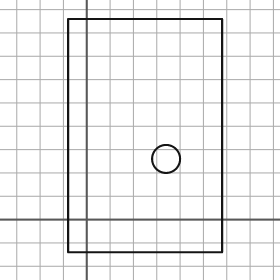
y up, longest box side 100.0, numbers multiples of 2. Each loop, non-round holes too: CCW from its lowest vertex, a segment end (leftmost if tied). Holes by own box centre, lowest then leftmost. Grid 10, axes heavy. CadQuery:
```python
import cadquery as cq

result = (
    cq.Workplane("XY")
    .moveTo(-8.0, -14.0)
    .lineTo(58.0, -14.0)
    .lineTo(58.0, 86.0)
    .lineTo(-8.0, 86.0)
    .close()
    .moveTo(34.0, 26.0)
    .circle(6.0)
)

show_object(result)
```